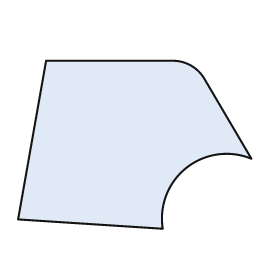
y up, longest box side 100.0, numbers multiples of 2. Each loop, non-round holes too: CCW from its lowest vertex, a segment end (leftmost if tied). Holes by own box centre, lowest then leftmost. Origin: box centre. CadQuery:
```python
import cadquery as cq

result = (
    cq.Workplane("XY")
    .moveTo(12.0, -36.0)
    .threePointArc((22.0, -10.0), (50.0, -6.0))
    .lineTo(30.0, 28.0)
    .threePointArc((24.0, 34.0), (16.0, 36.0))
    .lineTo(-38.0, 36.0)
    .lineTo(-50.0, -32.0)
    .close()
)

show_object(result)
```